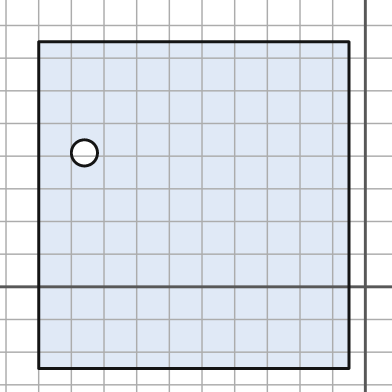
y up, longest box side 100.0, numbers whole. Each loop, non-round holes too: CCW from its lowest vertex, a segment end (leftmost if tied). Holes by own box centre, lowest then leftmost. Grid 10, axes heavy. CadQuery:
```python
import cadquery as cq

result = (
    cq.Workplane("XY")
    .moveTo(-100.0, -25.0)
    .lineTo(-5.0, -25.0)
    .lineTo(-5.0, 75.0)
    .lineTo(-100.0, 75.0)
    .close()
    .moveTo(-86.0, 41.0)
    .circle(4.0)
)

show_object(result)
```